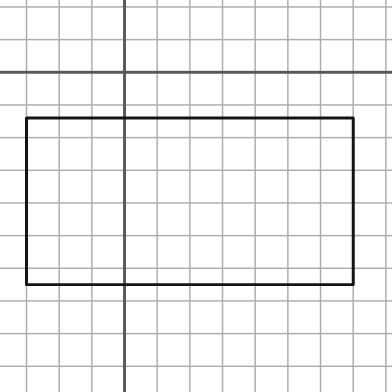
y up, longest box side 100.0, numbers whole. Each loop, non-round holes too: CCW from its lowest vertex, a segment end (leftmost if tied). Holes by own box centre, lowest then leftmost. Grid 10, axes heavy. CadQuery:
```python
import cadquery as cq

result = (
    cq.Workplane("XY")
    .moveTo(-30.0, -65.0)
    .lineTo(70.0, -65.0)
    .lineTo(70.0, -14.0)
    .lineTo(-30.0, -14.0)
    .close()
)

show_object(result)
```